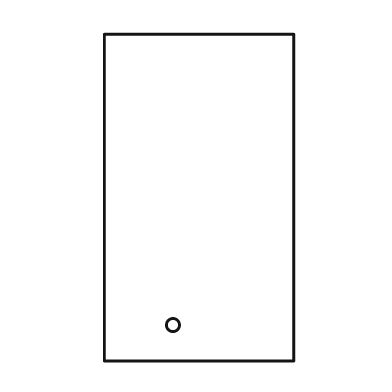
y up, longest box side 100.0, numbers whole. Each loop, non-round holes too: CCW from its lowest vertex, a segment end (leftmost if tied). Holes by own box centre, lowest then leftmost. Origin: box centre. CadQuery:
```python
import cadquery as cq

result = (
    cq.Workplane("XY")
    .moveTo(-29.0, -50.0)
    .lineTo(29.0, -50.0)
    .lineTo(29.0, 50.0)
    .lineTo(-29.0, 50.0)
    .close()
    .moveTo(-8.0, -39.0)
    .circle(2.0)
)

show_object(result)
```